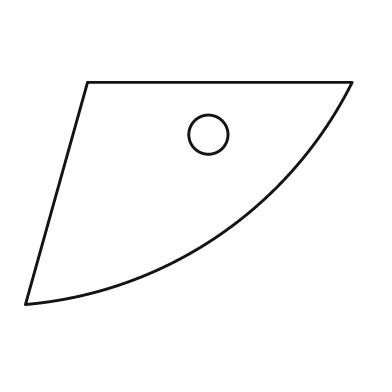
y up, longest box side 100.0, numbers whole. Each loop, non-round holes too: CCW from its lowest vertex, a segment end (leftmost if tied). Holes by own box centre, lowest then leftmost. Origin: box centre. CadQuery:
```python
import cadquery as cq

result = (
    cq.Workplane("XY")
    .moveTo(-50.0, -34.0)
    .threePointArc((9.0, -13.0), (50.0, 34.0))
    .lineTo(-31.0, 34.0)
    .close()
    .moveTo(6.0, 18.0)
    .circle(6.0)
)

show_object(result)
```